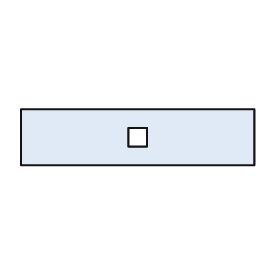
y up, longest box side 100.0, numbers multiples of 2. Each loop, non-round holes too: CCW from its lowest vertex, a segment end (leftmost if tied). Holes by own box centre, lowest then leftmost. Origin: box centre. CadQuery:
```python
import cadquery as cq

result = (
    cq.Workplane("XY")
    .moveTo(-50.0, -12.0)
    .lineTo(50.0, -12.0)
    .lineTo(50.0, 12.0)
    .lineTo(-50.0, 12.0)
    .close()
    .moveTo(-4.0, -4.0)
    .lineTo(4.0, -4.0)
    .lineTo(4.0, 4.0)
    .lineTo(-4.0, 4.0)
    .close()
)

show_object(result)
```